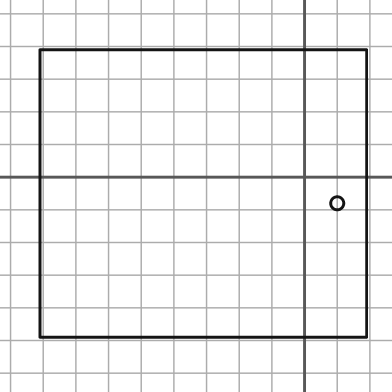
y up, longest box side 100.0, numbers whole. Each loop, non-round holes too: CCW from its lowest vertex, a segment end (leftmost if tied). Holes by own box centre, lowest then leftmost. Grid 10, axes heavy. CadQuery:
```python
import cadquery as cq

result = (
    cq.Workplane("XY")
    .moveTo(-81.0, -49.0)
    .lineTo(19.0, -49.0)
    .lineTo(19.0, 39.0)
    .lineTo(-81.0, 39.0)
    .close()
    .moveTo(10.0, -8.0)
    .circle(2.0)
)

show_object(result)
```